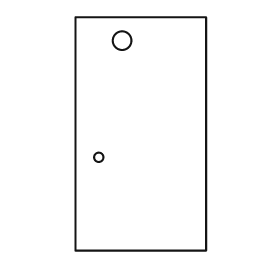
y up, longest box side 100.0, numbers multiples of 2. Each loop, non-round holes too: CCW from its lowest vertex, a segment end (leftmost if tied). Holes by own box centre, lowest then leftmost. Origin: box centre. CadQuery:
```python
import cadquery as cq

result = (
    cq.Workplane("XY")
    .moveTo(-28.0, -50.0)
    .lineTo(28.0, -50.0)
    .lineTo(28.0, 50.0)
    .lineTo(-28.0, 50.0)
    .close()
    .moveTo(-18.0, -10.0)
    .circle(2.0)
    .moveTo(-8.0, 40.0)
    .circle(4.0)
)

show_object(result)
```